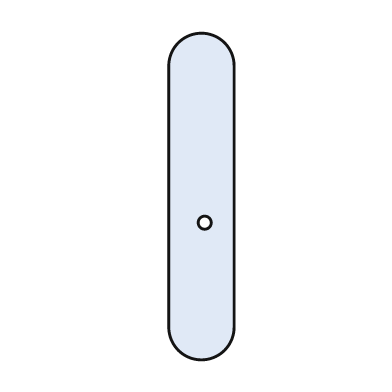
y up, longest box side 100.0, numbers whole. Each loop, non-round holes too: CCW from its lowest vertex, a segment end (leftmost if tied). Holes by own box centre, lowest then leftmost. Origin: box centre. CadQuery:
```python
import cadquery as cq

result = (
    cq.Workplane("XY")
    .moveTo(-10.0, -40.0)
    .threePointArc((0.0, -50.0), (10.0, -40.0))
    .lineTo(10.0, 40.0)
    .threePointArc((0.0, 50.0), (-10.0, 40.0))
    .close()
    .moveTo(1.0, -8.0)
    .circle(2.0)
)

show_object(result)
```